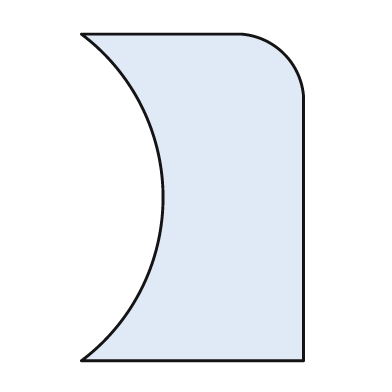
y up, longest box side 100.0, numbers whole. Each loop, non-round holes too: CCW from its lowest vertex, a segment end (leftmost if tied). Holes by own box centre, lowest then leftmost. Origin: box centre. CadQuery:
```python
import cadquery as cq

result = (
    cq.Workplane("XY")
    .moveTo(-34.0, -50.0)
    .lineTo(34.0, -50.0)
    .lineTo(34.0, 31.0)
    .threePointArc((28.0, 44.0), (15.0, 50.0))
    .lineTo(-34.0, 50.0)
    .threePointArc((-9.0, 0.0), (-34.0, -50.0))
    .close()
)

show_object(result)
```